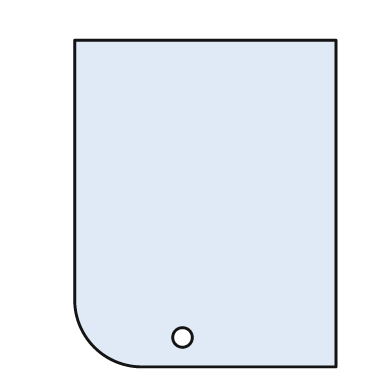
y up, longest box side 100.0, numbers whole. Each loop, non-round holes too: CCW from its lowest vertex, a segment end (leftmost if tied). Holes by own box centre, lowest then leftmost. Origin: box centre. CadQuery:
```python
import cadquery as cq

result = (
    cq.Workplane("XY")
    .moveTo(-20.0, -50.0)
    .lineTo(40.0, -50.0)
    .lineTo(40.0, 50.0)
    .lineTo(-40.0, 50.0)
    .lineTo(-40.0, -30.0)
    .threePointArc((-34.0, -44.0), (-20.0, -50.0))
    .close()
    .moveTo(-7.0, -41.0)
    .circle(3.0)
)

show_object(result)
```